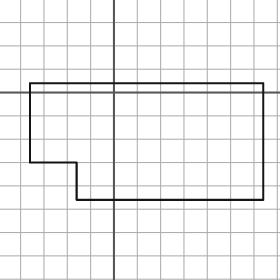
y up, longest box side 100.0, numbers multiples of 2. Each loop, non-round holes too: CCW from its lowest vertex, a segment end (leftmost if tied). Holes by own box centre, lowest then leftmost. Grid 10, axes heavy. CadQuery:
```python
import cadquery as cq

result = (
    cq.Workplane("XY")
    .moveTo(-16.0, -46.0)
    .lineTo(64.0, -46.0)
    .lineTo(64.0, 4.0)
    .lineTo(-36.0, 4.0)
    .lineTo(-36.0, -30.0)
    .lineTo(-16.0, -30.0)
    .close()
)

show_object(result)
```